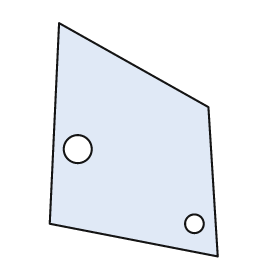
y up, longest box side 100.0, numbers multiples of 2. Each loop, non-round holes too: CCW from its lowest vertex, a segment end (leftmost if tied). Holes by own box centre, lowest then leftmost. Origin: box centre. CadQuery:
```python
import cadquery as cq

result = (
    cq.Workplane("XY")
    .moveTo(36.0, -50.0)
    .lineTo(32.0, 14.0)
    .lineTo(-32.0, 50.0)
    .lineTo(-36.0, -36.0)
    .close()
    .moveTo(26.0, -36.0)
    .circle(4.0)
    .moveTo(-24.0, -4.0)
    .circle(6.0)
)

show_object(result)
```